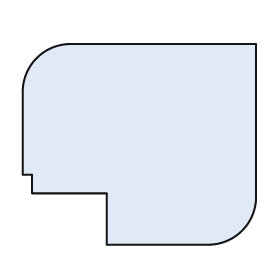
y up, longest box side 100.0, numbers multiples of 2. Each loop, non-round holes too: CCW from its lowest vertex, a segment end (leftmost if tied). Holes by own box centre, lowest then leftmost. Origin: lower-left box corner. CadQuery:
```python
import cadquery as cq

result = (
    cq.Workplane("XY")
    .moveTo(36.0, 0.0)
    .lineTo(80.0, 0.0)
    .threePointArc((94.0, 6.0), (100.0, 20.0))
    .lineTo(100.0, 86.0)
    .lineTo(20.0, 86.0)
    .threePointArc((6.0, 80.0), (0.0, 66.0))
    .lineTo(0.0, 30.0)
    .lineTo(4.0, 30.0)
    .lineTo(4.0, 22.0)
    .lineTo(36.0, 22.0)
    .close()
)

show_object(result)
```